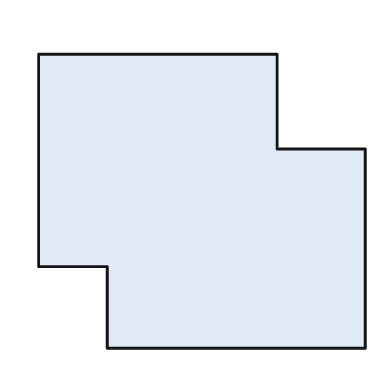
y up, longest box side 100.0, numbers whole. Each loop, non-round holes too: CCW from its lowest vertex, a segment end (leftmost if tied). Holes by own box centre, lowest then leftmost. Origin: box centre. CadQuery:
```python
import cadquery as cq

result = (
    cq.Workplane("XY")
    .moveTo(-29.0, -45.0)
    .lineTo(50.0, -45.0)
    .lineTo(50.0, 16.0)
    .lineTo(23.0, 16.0)
    .lineTo(23.0, 45.0)
    .lineTo(-50.0, 45.0)
    .lineTo(-50.0, -20.0)
    .lineTo(-29.0, -20.0)
    .close()
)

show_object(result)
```